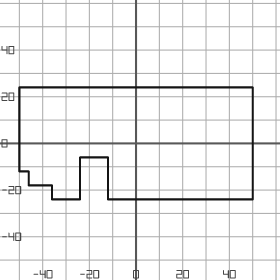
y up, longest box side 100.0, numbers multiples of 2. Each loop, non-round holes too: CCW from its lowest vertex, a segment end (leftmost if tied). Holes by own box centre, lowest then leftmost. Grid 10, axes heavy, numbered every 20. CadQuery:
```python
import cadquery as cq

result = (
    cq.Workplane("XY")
    .moveTo(-36.0, -24.0)
    .lineTo(-24.0, -24.0)
    .lineTo(-24.0, -6.0)
    .lineTo(-12.0, -6.0)
    .lineTo(-12.0, -24.0)
    .lineTo(50.0, -24.0)
    .lineTo(50.0, 24.0)
    .lineTo(-50.0, 24.0)
    .lineTo(-50.0, -12.0)
    .lineTo(-46.0, -12.0)
    .lineTo(-46.0, -18.0)
    .lineTo(-36.0, -18.0)
    .close()
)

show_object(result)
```